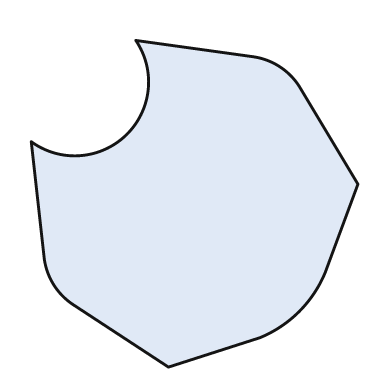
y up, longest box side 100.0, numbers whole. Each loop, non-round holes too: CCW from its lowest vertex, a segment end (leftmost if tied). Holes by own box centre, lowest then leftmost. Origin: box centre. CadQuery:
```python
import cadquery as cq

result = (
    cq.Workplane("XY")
    .moveTo(-8.0, -50.0)
    .lineTo(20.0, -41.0)
    .threePointArc((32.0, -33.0), (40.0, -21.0))
    .lineTo(50.0, 6.0)
    .lineTo(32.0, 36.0)
    .threePointArc((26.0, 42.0), (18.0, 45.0))
    .lineTo(-18.0, 50.0)
    .threePointArc((-21.0, 21.0), (-50.0, 19.0))
    .lineTo(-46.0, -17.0)
    .threePointArc((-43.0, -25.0), (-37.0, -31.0))
    .close()
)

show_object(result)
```